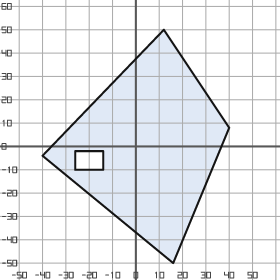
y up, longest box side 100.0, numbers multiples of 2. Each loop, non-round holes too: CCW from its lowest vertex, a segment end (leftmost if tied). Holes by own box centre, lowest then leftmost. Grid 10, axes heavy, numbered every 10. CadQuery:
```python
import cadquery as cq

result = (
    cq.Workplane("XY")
    .moveTo(16.0, -50.0)
    .lineTo(40.0, 8.0)
    .lineTo(12.0, 50.0)
    .lineTo(-40.0, -4.0)
    .close()
    .moveTo(-26.0, -10.0)
    .lineTo(-14.0, -10.0)
    .lineTo(-14.0, -2.0)
    .lineTo(-26.0, -2.0)
    .close()
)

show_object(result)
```